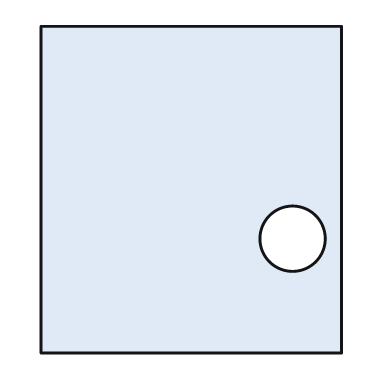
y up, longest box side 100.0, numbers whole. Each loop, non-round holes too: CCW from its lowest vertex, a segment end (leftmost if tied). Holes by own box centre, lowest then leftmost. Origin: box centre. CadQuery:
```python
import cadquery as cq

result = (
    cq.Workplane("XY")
    .moveTo(-46.0, -50.0)
    .lineTo(46.0, -50.0)
    .lineTo(46.0, 50.0)
    .lineTo(-46.0, 50.0)
    .close()
    .moveTo(31.0, -15.0)
    .circle(10.0)
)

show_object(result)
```